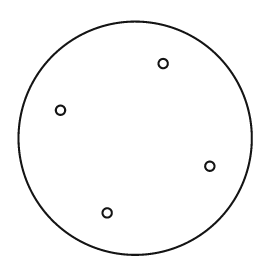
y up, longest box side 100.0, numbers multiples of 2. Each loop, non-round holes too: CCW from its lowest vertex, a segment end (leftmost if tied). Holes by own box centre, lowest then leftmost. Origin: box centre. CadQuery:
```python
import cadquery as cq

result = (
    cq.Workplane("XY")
    .moveTo(0.0, 0.0)
    .circle(50.0)
    .moveTo(-12.0, -32.0)
    .circle(2.0)
    .moveTo(32.0, -12.0)
    .circle(2.0)
    .moveTo(-32.0, 12.0)
    .circle(2.0)
    .moveTo(12.0, 32.0)
    .circle(2.0)
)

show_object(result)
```